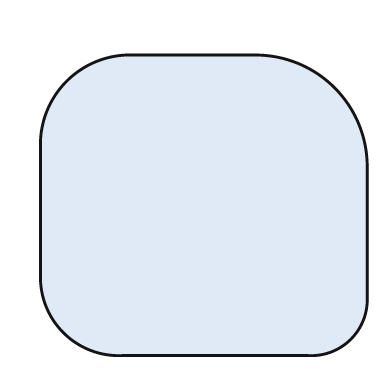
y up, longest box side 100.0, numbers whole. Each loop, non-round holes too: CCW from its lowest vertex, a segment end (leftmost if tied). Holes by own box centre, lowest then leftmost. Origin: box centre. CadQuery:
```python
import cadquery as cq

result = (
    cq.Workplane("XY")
    .moveTo(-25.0, -46.0)
    .lineTo(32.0, -46.0)
    .threePointArc((45.0, -41.0), (50.0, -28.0))
    .lineTo(50.0, 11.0)
    .threePointArc((40.0, 36.0), (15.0, 46.0))
    .lineTo(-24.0, 46.0)
    .threePointArc((-42.0, 38.0), (-50.0, 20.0))
    .lineTo(-50.0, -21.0)
    .threePointArc((-43.0, -39.0), (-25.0, -46.0))
    .close()
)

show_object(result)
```